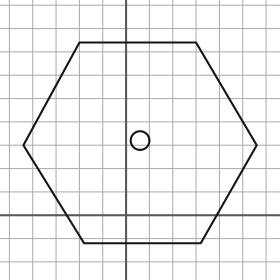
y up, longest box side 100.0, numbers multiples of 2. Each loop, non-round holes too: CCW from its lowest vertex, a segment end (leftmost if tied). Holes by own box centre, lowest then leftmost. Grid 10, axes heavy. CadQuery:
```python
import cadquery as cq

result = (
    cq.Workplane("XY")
    .moveTo(-18.0, -12.0)
    .lineTo(32.0, -12.0)
    .lineTo(56.0, 30.0)
    .lineTo(30.0, 74.0)
    .lineTo(-20.0, 74.0)
    .lineTo(-44.0, 30.0)
    .close()
    .moveTo(6.0, 32.0)
    .circle(4.0)
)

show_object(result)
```